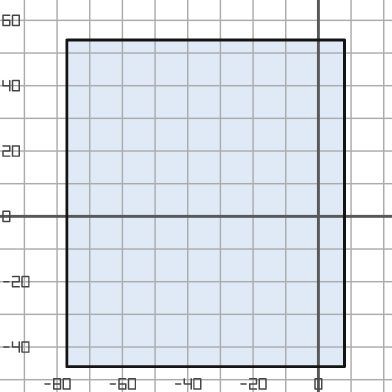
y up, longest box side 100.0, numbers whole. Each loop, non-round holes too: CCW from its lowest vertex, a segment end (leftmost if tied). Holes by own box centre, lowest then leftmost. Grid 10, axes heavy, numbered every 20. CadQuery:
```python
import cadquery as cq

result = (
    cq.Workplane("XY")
    .moveTo(-77.0, -46.0)
    .lineTo(8.0, -46.0)
    .lineTo(8.0, 54.0)
    .lineTo(-77.0, 54.0)
    .close()
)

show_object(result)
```